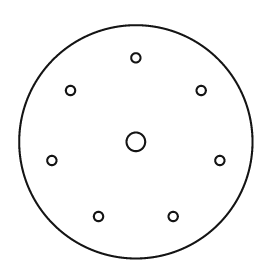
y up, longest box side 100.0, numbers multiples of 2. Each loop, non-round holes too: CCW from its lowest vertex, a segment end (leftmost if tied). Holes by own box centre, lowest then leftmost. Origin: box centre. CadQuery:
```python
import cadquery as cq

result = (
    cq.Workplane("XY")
    .moveTo(0.0, 0.0)
    .circle(50.0)
    .moveTo(-16.0, -32.0)
    .circle(2.0)
    .moveTo(16.0, -32.0)
    .circle(2.0)
    .moveTo(-36.0, -8.0)
    .circle(2.0)
    .moveTo(36.0, -8.0)
    .circle(2.0)
    .moveTo(0.0, 0.0)
    .circle(4.0)
    .moveTo(-28.0, 22.0)
    .circle(2.0)
    .moveTo(28.0, 22.0)
    .circle(2.0)
    .moveTo(0.0, 36.0)
    .circle(2.0)
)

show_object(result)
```